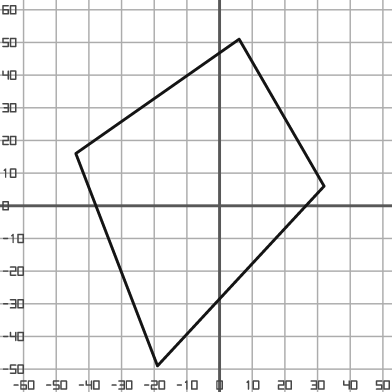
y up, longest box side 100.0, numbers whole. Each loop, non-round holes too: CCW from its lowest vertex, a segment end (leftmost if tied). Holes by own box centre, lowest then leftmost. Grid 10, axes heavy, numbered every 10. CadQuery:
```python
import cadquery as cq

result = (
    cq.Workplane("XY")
    .moveTo(-19.0, -49.0)
    .lineTo(32.0, 6.0)
    .lineTo(6.0, 51.0)
    .lineTo(-44.0, 16.0)
    .close()
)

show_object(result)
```